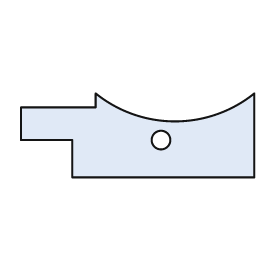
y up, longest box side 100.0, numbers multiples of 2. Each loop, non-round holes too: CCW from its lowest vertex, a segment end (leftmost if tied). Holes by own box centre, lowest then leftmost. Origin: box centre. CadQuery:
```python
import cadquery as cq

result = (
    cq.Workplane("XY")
    .moveTo(-28.0, -18.0)
    .lineTo(50.0, -18.0)
    .lineTo(50.0, 18.0)
    .threePointArc((16.0, 6.0), (-18.0, 18.0))
    .lineTo(-18.0, 12.0)
    .lineTo(-50.0, 12.0)
    .lineTo(-50.0, -2.0)
    .lineTo(-28.0, -2.0)
    .close()
    .moveTo(10.0, -2.0)
    .circle(4.0)
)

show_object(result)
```